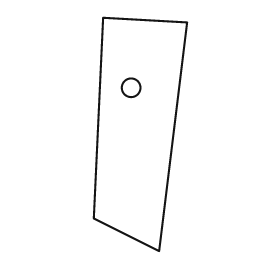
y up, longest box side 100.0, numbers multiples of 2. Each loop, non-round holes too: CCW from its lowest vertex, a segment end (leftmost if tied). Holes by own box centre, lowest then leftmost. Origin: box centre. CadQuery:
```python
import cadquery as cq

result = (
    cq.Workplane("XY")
    .moveTo(8.0, -50.0)
    .lineTo(20.0, 48.0)
    .lineTo(-16.0, 50.0)
    .lineTo(-20.0, -36.0)
    .close()
    .moveTo(-4.0, 20.0)
    .circle(4.0)
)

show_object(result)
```